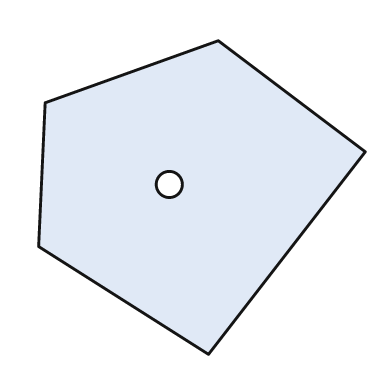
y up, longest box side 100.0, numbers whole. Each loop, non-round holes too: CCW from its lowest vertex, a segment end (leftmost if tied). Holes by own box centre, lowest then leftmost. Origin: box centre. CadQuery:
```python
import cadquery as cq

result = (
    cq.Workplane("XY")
    .moveTo(2.0, -48.0)
    .lineTo(50.0, 14.0)
    .lineTo(5.0, 48.0)
    .lineTo(-48.0, 29.0)
    .lineTo(-50.0, -15.0)
    .close()
    .moveTo(-10.0, 4.0)
    .circle(4.0)
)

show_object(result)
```